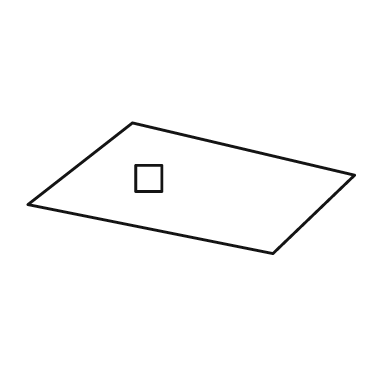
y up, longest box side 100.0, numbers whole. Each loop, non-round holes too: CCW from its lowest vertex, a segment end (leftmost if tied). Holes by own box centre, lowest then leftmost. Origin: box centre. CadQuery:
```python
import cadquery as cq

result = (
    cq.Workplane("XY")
    .moveTo(25.0, -20.0)
    .lineTo(50.0, 4.0)
    .lineTo(-18.0, 20.0)
    .lineTo(-50.0, -5.0)
    .close()
    .moveTo(-17.0, -1.0)
    .lineTo(-9.0, -1.0)
    .lineTo(-9.0, 7.0)
    .lineTo(-17.0, 7.0)
    .close()
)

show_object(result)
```